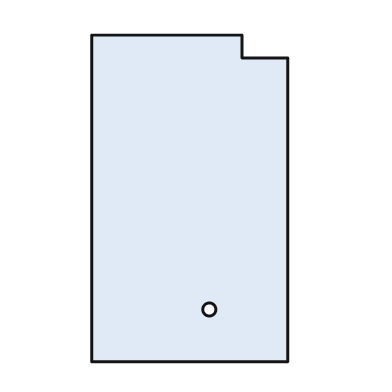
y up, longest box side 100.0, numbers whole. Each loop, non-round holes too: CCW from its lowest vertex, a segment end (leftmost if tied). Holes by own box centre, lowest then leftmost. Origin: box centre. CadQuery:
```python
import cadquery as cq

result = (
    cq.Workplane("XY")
    .moveTo(-30.0, -50.0)
    .lineTo(30.0, -50.0)
    .lineTo(30.0, 43.0)
    .lineTo(16.0, 43.0)
    .lineTo(16.0, 50.0)
    .lineTo(-30.0, 50.0)
    .close()
    .moveTo(6.0, -34.0)
    .circle(2.0)
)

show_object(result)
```